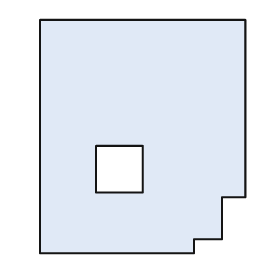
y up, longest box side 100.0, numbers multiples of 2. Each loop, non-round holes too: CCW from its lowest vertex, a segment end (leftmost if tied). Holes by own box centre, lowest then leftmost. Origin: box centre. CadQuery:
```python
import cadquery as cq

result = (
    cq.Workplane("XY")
    .moveTo(-44.0, -50.0)
    .lineTo(22.0, -50.0)
    .lineTo(22.0, -44.0)
    .lineTo(34.0, -44.0)
    .lineTo(34.0, -26.0)
    .lineTo(44.0, -26.0)
    .lineTo(44.0, 50.0)
    .lineTo(-44.0, 50.0)
    .close()
    .moveTo(-20.0, -24.0)
    .lineTo(0.0, -24.0)
    .lineTo(0.0, -4.0)
    .lineTo(-20.0, -4.0)
    .close()
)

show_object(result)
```